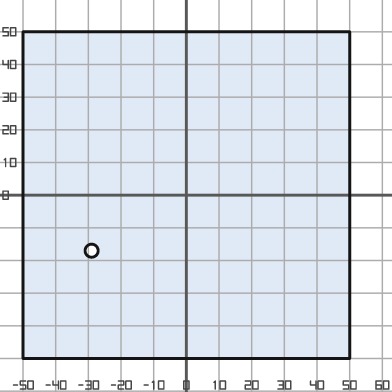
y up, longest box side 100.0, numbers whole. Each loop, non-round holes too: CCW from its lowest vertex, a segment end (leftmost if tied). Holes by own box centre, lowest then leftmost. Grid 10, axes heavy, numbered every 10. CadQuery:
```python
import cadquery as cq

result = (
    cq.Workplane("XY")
    .moveTo(-50.0, -50.0)
    .lineTo(50.0, -50.0)
    .lineTo(50.0, 50.0)
    .lineTo(-50.0, 50.0)
    .close()
    .moveTo(-29.0, -17.0)
    .circle(2.0)
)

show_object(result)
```